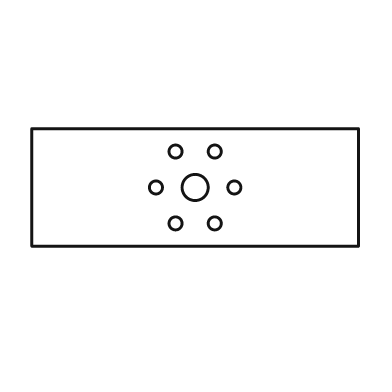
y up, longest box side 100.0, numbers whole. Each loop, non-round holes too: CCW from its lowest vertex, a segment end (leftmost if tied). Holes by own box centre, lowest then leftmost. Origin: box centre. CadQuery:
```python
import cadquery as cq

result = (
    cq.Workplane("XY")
    .moveTo(-50.0, -18.0)
    .lineTo(50.0, -18.0)
    .lineTo(50.0, 18.0)
    .lineTo(-50.0, 18.0)
    .close()
    .moveTo(-6.0, -11.0)
    .circle(2.0)
    .moveTo(6.0, -11.0)
    .circle(2.0)
    .moveTo(-12.0, 0.0)
    .circle(2.0)
    .moveTo(0.0, 0.0)
    .circle(4.0)
    .moveTo(12.0, 0.0)
    .circle(2.0)
    .moveTo(-6.0, 11.0)
    .circle(2.0)
    .moveTo(6.0, 11.0)
    .circle(2.0)
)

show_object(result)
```